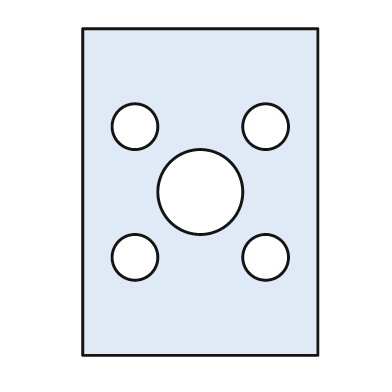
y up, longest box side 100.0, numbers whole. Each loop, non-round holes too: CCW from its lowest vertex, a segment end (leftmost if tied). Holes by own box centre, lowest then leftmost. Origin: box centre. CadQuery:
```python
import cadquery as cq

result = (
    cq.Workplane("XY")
    .moveTo(-36.0, -50.0)
    .lineTo(36.0, -50.0)
    .lineTo(36.0, 50.0)
    .lineTo(-36.0, 50.0)
    .close()
    .moveTo(-20.0, -20.0)
    .circle(7.0)
    .moveTo(20.0, -20.0)
    .circle(7.0)
    .moveTo(0.0, 0.0)
    .circle(13.0)
    .moveTo(-20.0, 20.0)
    .circle(7.0)
    .moveTo(20.0, 20.0)
    .circle(7.0)
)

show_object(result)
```